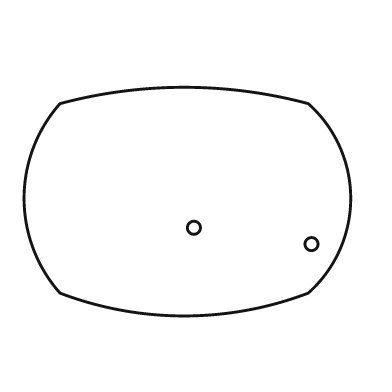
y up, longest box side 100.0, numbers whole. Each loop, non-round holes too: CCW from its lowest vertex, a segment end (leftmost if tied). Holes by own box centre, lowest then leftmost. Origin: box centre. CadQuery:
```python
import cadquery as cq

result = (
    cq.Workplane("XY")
    .moveTo(-39.0, -28.0)
    .threePointArc((-1.0, -35.0), (37.0, -28.0))
    .threePointArc((50.0, 1.0), (37.0, 30.0))
    .threePointArc((-1.0, 35.0), (-39.0, 30.0))
    .threePointArc((-50.0, 1.0), (-39.0, -28.0))
    .close()
    .moveTo(38.0, -13.0)
    .circle(2.0)
    .moveTo(2.0, -8.0)
    .circle(2.0)
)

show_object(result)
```